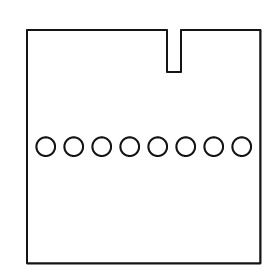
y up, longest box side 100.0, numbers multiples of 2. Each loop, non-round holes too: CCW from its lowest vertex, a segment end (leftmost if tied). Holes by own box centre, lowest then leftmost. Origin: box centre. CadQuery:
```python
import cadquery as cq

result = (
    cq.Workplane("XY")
    .moveTo(-50.0, -50.0)
    .lineTo(50.0, -50.0)
    .lineTo(50.0, 50.0)
    .lineTo(16.0, 50.0)
    .lineTo(16.0, 32.0)
    .lineTo(10.0, 32.0)
    .lineTo(10.0, 50.0)
    .lineTo(-50.0, 50.0)
    .close()
    .moveTo(-42.0, 0.0)
    .circle(4.0)
    .moveTo(-30.0, 0.0)
    .circle(4.0)
    .moveTo(-18.0, 0.0)
    .circle(4.0)
    .moveTo(-6.0, 0.0)
    .circle(4.0)
    .moveTo(6.0, 0.0)
    .circle(4.0)
    .moveTo(18.0, 0.0)
    .circle(4.0)
    .moveTo(30.0, 0.0)
    .circle(4.0)
    .moveTo(42.0, 0.0)
    .circle(4.0)
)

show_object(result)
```